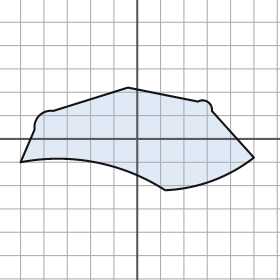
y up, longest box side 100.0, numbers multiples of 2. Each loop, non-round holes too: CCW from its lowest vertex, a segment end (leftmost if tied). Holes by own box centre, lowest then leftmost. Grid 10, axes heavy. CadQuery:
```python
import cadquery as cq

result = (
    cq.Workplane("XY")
    .moveTo(12.0, -22.0)
    .threePointArc((32.0, -18.0), (50.0, -8.0))
    .lineTo(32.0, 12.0)
    .threePointArc((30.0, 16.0), (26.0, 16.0))
    .lineTo(-4.0, 22.0)
    .lineTo(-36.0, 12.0)
    .threePointArc((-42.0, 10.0), (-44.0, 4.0))
    .lineTo(-50.0, -10.0)
    .threePointArc((-18.0, -10.0), (12.0, -22.0))
    .close()
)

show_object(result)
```